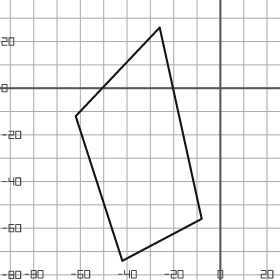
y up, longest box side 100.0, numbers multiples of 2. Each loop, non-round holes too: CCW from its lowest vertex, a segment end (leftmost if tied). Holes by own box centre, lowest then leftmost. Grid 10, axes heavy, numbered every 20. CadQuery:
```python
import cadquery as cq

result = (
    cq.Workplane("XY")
    .moveTo(-42.0, -74.0)
    .lineTo(-8.0, -56.0)
    .lineTo(-26.0, 26.0)
    .lineTo(-62.0, -12.0)
    .close()
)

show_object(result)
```